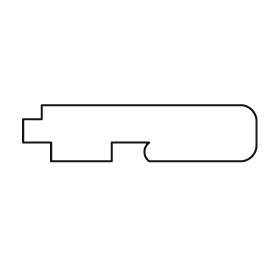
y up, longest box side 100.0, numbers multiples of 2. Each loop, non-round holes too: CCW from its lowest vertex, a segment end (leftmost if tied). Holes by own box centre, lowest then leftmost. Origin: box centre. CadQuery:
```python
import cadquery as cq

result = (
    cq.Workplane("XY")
    .moveTo(-38.0, -12.0)
    .lineTo(-12.0, -12.0)
    .lineTo(-12.0, -4.0)
    .lineTo(4.0, -4.0)
    .threePointArc((2.0, -8.0), (4.0, -12.0))
    .lineTo(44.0, -12.0)
    .threePointArc((48.0, -10.0), (50.0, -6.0))
    .lineTo(50.0, 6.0)
    .threePointArc((48.0, 10.0), (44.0, 12.0))
    .lineTo(-42.0, 12.0)
    .lineTo(-42.0, 6.0)
    .lineTo(-50.0, 6.0)
    .lineTo(-50.0, -4.0)
    .lineTo(-38.0, -4.0)
    .close()
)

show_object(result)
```